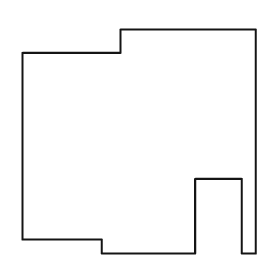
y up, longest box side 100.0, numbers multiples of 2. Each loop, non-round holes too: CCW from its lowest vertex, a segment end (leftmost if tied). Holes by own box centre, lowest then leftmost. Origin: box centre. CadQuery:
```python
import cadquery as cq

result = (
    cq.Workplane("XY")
    .moveTo(-16.0, -48.0)
    .lineTo(24.0, -48.0)
    .lineTo(24.0, -16.0)
    .lineTo(44.0, -16.0)
    .lineTo(44.0, -48.0)
    .lineTo(50.0, -48.0)
    .lineTo(50.0, 48.0)
    .lineTo(-8.0, 48.0)
    .lineTo(-8.0, 38.0)
    .lineTo(-50.0, 38.0)
    .lineTo(-50.0, -42.0)
    .lineTo(-16.0, -42.0)
    .close()
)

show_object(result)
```